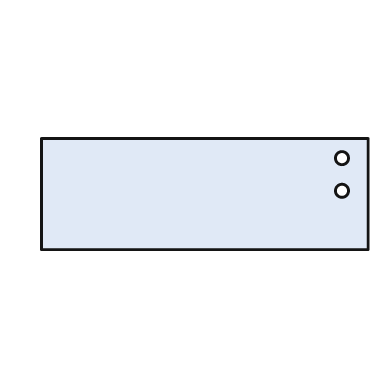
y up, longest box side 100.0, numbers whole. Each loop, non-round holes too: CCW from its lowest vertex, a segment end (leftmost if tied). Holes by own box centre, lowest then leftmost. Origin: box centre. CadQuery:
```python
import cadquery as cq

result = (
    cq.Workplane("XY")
    .moveTo(-50.0, -17.0)
    .lineTo(50.0, -17.0)
    .lineTo(50.0, 17.0)
    .lineTo(-50.0, 17.0)
    .close()
    .moveTo(42.0, 1.0)
    .circle(2.0)
    .moveTo(42.0, 11.0)
    .circle(2.0)
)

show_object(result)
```